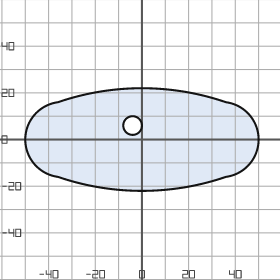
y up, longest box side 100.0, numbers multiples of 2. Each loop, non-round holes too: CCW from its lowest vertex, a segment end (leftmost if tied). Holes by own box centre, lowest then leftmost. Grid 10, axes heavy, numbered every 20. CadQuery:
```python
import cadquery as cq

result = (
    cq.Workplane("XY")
    .moveTo(-36.0, -16.0)
    .threePointArc((0.0, -22.0), (36.0, -16.0))
    .threePointArc((50.0, 0.0), (36.0, 16.0))
    .threePointArc((0.0, 22.0), (-36.0, 16.0))
    .threePointArc((-50.0, 0.0), (-36.0, -16.0))
    .close()
    .moveTo(-4.0, 6.0)
    .circle(4.0)
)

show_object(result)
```